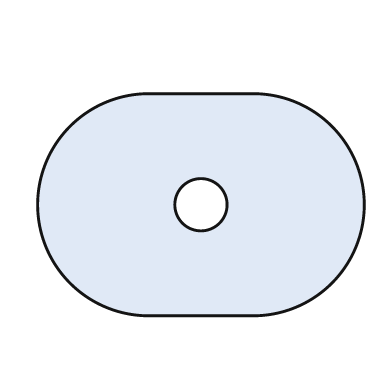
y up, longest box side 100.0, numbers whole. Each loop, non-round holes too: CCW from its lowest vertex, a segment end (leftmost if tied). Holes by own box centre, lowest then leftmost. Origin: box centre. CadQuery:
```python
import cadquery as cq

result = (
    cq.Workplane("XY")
    .moveTo(-16.0, -34.0)
    .lineTo(16.0, -34.0)
    .threePointArc((50.0, 0.0), (16.0, 34.0))
    .lineTo(-16.0, 34.0)
    .threePointArc((-50.0, 0.0), (-16.0, -34.0))
    .close()
    .moveTo(0.0, 0.0)
    .circle(8.0)
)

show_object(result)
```